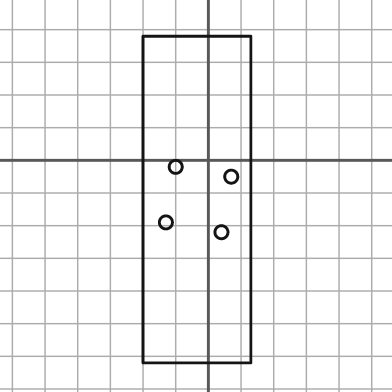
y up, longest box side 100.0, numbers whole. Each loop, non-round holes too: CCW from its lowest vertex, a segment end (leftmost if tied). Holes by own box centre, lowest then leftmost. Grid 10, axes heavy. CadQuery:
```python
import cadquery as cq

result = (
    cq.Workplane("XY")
    .moveTo(-20.0, -62.0)
    .lineTo(13.0, -62.0)
    .lineTo(13.0, 38.0)
    .lineTo(-20.0, 38.0)
    .close()
    .moveTo(4.0, -22.0)
    .circle(2.0)
    .moveTo(-13.0, -19.0)
    .circle(2.0)
    .moveTo(7.0, -5.0)
    .circle(2.0)
    .moveTo(-10.0, -2.0)
    .circle(2.0)
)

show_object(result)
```